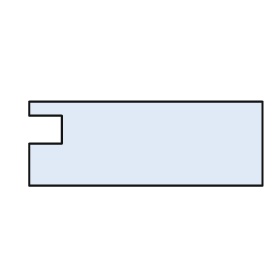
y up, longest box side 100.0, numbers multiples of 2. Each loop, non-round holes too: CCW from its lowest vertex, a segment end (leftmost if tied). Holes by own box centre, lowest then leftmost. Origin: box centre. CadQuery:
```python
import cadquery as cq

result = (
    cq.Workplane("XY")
    .moveTo(-50.0, -18.0)
    .lineTo(50.0, -18.0)
    .lineTo(50.0, 18.0)
    .lineTo(-50.0, 18.0)
    .lineTo(-50.0, 12.0)
    .lineTo(-36.0, 12.0)
    .lineTo(-36.0, 0.0)
    .lineTo(-50.0, 0.0)
    .close()
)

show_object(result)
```